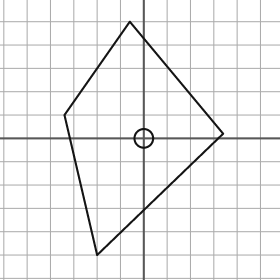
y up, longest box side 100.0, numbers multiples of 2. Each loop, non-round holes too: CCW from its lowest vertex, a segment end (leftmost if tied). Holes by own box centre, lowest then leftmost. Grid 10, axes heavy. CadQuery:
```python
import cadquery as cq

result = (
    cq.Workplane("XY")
    .moveTo(-20.0, -50.0)
    .lineTo(34.0, 2.0)
    .lineTo(-6.0, 50.0)
    .lineTo(-34.0, 10.0)
    .close()
    .moveTo(0.0, 0.0)
    .circle(4.0)
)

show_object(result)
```